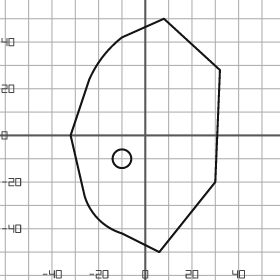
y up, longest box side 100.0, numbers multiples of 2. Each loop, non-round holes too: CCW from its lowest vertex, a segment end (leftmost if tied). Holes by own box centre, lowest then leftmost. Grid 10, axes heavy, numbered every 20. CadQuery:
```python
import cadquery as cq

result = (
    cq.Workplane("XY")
    .moveTo(6.0, -50.0)
    .lineTo(30.0, -20.0)
    .lineTo(32.0, 28.0)
    .lineTo(8.0, 50.0)
    .lineTo(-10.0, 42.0)
    .threePointArc((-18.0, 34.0), (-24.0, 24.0))
    .lineTo(-32.0, 0.0)
    .lineTo(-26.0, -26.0)
    .threePointArc((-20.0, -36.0), (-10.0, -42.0))
    .close()
    .moveTo(-10.0, -10.0)
    .circle(4.0)
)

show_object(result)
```